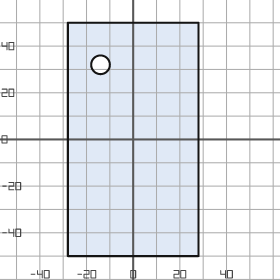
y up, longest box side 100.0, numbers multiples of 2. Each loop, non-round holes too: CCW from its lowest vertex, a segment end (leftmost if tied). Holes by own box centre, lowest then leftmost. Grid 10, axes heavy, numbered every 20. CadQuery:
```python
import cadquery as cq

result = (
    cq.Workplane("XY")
    .moveTo(-28.0, -50.0)
    .lineTo(28.0, -50.0)
    .lineTo(28.0, 50.0)
    .lineTo(-28.0, 50.0)
    .close()
    .moveTo(-14.0, 32.0)
    .circle(4.0)
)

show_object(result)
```